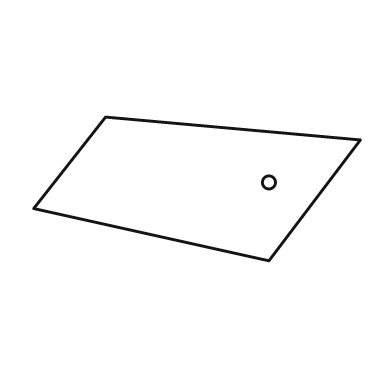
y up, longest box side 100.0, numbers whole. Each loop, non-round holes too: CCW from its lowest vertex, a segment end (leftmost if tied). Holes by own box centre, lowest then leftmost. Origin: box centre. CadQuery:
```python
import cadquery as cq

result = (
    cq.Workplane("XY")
    .moveTo(22.0, -22.0)
    .lineTo(50.0, 15.0)
    .lineTo(-28.0, 22.0)
    .lineTo(-50.0, -6.0)
    .close()
    .moveTo(22.0, 2.0)
    .circle(2.0)
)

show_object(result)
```